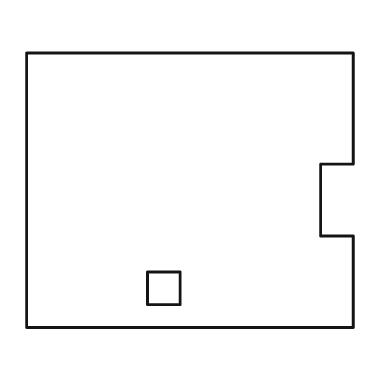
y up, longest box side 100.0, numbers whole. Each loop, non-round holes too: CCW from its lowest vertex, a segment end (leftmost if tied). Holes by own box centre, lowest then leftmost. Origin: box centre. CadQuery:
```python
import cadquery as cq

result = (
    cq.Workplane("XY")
    .moveTo(-50.0, -42.0)
    .lineTo(50.0, -42.0)
    .lineTo(50.0, -14.0)
    .lineTo(40.0, -14.0)
    .lineTo(40.0, 8.0)
    .lineTo(50.0, 8.0)
    .lineTo(50.0, 42.0)
    .lineTo(-50.0, 42.0)
    .close()
    .moveTo(-13.0, -35.0)
    .lineTo(-3.0, -35.0)
    .lineTo(-3.0, -25.0)
    .lineTo(-13.0, -25.0)
    .close()
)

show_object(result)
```